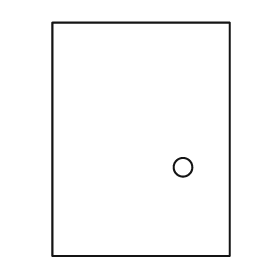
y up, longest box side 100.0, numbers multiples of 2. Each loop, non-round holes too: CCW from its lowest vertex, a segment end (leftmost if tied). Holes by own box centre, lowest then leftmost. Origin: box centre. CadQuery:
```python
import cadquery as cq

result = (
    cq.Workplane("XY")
    .moveTo(-38.0, -50.0)
    .lineTo(38.0, -50.0)
    .lineTo(38.0, 50.0)
    .lineTo(-38.0, 50.0)
    .close()
    .moveTo(18.0, -12.0)
    .circle(4.0)
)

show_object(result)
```